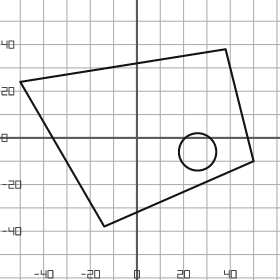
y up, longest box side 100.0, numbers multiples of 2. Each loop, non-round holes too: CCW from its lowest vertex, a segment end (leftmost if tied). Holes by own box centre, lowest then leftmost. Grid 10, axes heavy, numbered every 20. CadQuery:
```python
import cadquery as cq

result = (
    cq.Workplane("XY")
    .moveTo(-14.0, -38.0)
    .lineTo(50.0, -10.0)
    .lineTo(38.0, 38.0)
    .lineTo(-50.0, 24.0)
    .close()
    .moveTo(26.0, -6.0)
    .circle(8.0)
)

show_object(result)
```